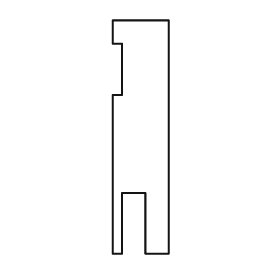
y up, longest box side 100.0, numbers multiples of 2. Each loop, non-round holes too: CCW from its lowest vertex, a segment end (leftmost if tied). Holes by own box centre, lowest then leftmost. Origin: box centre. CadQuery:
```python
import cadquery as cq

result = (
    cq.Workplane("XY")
    .moveTo(-12.0, -50.0)
    .lineTo(-8.0, -50.0)
    .lineTo(-8.0, -24.0)
    .lineTo(2.0, -24.0)
    .lineTo(2.0, -50.0)
    .lineTo(12.0, -50.0)
    .lineTo(12.0, 50.0)
    .lineTo(-12.0, 50.0)
    .lineTo(-12.0, 40.0)
    .lineTo(-8.0, 40.0)
    .lineTo(-8.0, 18.0)
    .lineTo(-12.0, 18.0)
    .close()
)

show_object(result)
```